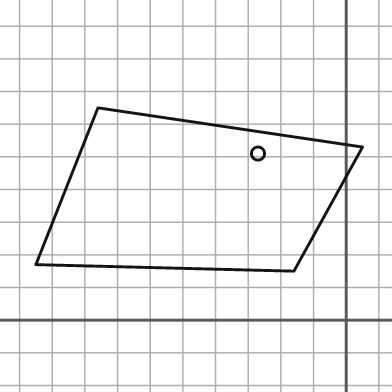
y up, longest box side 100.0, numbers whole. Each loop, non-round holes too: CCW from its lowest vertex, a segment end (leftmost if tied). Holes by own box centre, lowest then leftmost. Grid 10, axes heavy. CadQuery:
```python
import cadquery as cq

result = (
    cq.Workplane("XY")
    .moveTo(-16.0, 15.0)
    .lineTo(5.0, 53.0)
    .lineTo(-76.0, 65.0)
    .lineTo(-95.0, 17.0)
    .close()
    .moveTo(-27.0, 51.0)
    .circle(2.0)
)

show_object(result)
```